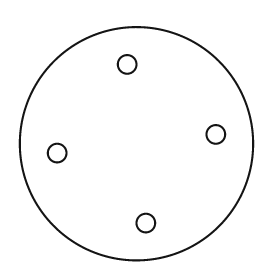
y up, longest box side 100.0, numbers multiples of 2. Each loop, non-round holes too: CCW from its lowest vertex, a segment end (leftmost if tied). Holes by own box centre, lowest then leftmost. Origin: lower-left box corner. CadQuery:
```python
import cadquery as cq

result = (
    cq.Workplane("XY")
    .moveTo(50.0, 50.0)
    .circle(50.0)
    .moveTo(54.0, 16.0)
    .circle(4.0)
    .moveTo(16.0, 46.0)
    .circle(4.0)
    .moveTo(84.0, 54.0)
    .circle(4.0)
    .moveTo(46.0, 84.0)
    .circle(4.0)
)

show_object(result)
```